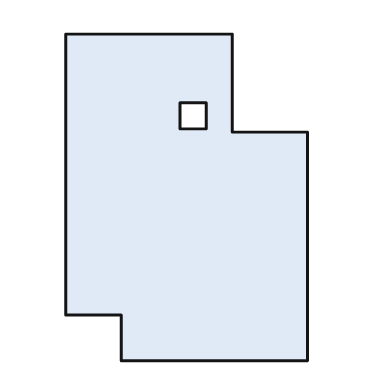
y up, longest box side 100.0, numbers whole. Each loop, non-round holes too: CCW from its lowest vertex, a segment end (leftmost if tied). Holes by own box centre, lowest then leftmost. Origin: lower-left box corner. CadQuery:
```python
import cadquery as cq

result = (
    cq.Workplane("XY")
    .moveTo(17.0, 0.0)
    .lineTo(74.0, 0.0)
    .lineTo(74.0, 70.0)
    .lineTo(51.0, 70.0)
    .lineTo(51.0, 100.0)
    .lineTo(0.0, 100.0)
    .lineTo(0.0, 14.0)
    .lineTo(17.0, 14.0)
    .close()
    .moveTo(35.0, 71.0)
    .lineTo(43.0, 71.0)
    .lineTo(43.0, 79.0)
    .lineTo(35.0, 79.0)
    .close()
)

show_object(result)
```